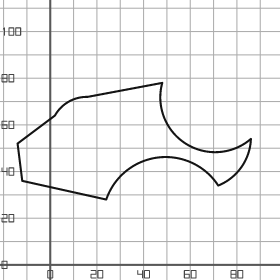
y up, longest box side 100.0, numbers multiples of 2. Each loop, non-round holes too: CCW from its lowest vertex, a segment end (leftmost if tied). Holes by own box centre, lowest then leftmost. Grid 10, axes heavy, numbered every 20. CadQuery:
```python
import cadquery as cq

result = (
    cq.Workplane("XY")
    .moveTo(24.0, 28.0)
    .threePointArc((46.0, 46.0), (72.0, 34.0))
    .threePointArc((82.0, 42.0), (86.0, 54.0))
    .threePointArc((58.0, 52.0), (48.0, 78.0))
    .lineTo(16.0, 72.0)
    .threePointArc((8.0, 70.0), (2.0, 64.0))
    .lineTo(-14.0, 52.0)
    .lineTo(-12.0, 36.0)
    .close()
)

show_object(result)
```